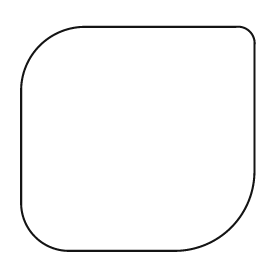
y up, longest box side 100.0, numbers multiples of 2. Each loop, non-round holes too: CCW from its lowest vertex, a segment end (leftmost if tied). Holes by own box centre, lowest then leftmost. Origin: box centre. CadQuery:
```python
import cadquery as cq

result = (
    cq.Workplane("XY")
    .moveTo(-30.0, -48.0)
    .lineTo(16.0, -48.0)
    .threePointArc((40.0, -38.0), (50.0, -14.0))
    .lineTo(50.0, 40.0)
    .threePointArc((48.0, 46.0), (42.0, 48.0))
    .lineTo(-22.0, 48.0)
    .threePointArc((-42.0, 40.0), (-50.0, 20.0))
    .lineTo(-50.0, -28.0)
    .threePointArc((-44.0, -42.0), (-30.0, -48.0))
    .close()
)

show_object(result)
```